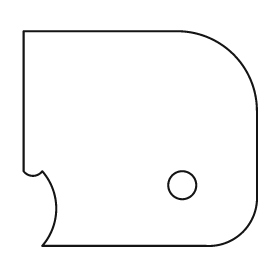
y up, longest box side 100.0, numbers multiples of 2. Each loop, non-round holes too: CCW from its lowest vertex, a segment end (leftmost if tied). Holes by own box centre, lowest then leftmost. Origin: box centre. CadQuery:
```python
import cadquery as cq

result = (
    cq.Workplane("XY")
    .moveTo(-42.0, -46.0)
    .lineTo(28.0, -46.0)
    .threePointArc((44.0, -40.0), (50.0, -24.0))
    .lineTo(50.0, 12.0)
    .threePointArc((40.0, 36.0), (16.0, 46.0))
    .lineTo(-50.0, 46.0)
    .lineTo(-50.0, -14.0)
    .threePointArc((-46.0, -16.0), (-42.0, -14.0))
    .threePointArc((-36.0, -30.0), (-42.0, -46.0))
    .close()
    .moveTo(18.0, -20.0)
    .circle(6.0)
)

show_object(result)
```